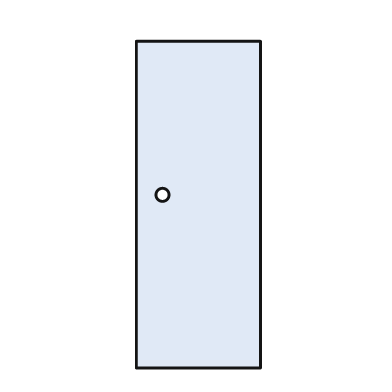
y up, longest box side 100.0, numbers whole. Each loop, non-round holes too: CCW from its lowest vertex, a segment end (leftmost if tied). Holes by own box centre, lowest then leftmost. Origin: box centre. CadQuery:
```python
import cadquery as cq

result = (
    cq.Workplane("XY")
    .moveTo(-19.0, -50.0)
    .lineTo(19.0, -50.0)
    .lineTo(19.0, 50.0)
    .lineTo(-19.0, 50.0)
    .close()
    .moveTo(-11.0, 3.0)
    .circle(2.0)
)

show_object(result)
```